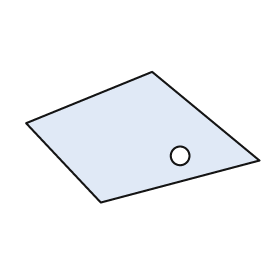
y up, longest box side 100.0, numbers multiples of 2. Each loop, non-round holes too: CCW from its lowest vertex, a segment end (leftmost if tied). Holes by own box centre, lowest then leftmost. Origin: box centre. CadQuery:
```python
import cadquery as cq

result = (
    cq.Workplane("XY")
    .moveTo(-18.0, -28.0)
    .lineTo(50.0, -10.0)
    .lineTo(4.0, 28.0)
    .lineTo(-50.0, 6.0)
    .close()
    .moveTo(16.0, -8.0)
    .circle(4.0)
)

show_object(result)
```